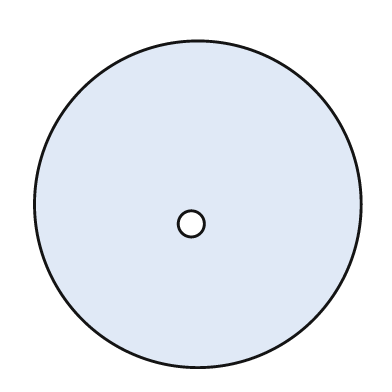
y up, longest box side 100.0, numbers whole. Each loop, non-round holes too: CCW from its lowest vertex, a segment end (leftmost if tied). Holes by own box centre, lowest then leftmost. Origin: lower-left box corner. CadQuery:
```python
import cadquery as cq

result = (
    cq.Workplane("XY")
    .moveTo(50.0, 50.0)
    .circle(50.0)
    .moveTo(48.0, 44.0)
    .circle(4.0)
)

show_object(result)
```